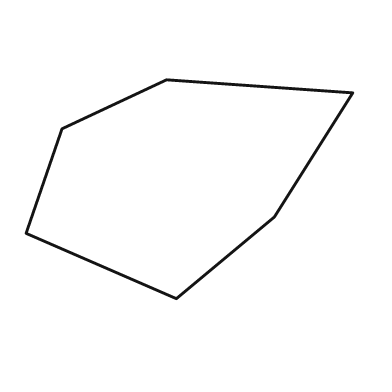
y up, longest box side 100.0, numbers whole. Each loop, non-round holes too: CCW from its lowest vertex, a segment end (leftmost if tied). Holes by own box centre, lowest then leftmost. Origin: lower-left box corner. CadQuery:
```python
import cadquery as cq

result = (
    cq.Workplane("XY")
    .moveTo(46.0, 0.0)
    .lineTo(76.0, 25.0)
    .lineTo(100.0, 63.0)
    .lineTo(43.0, 67.0)
    .lineTo(11.0, 52.0)
    .lineTo(0.0, 20.0)
    .close()
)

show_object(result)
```